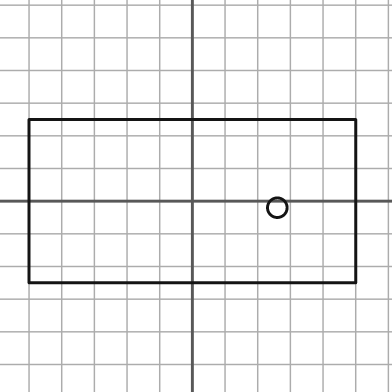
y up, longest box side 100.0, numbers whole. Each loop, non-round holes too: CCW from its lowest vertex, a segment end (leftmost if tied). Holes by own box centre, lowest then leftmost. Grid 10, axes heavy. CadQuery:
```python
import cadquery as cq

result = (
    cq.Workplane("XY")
    .moveTo(-50.0, -25.0)
    .lineTo(50.0, -25.0)
    .lineTo(50.0, 25.0)
    .lineTo(-50.0, 25.0)
    .close()
    .moveTo(26.0, -2.0)
    .circle(3.0)
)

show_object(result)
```